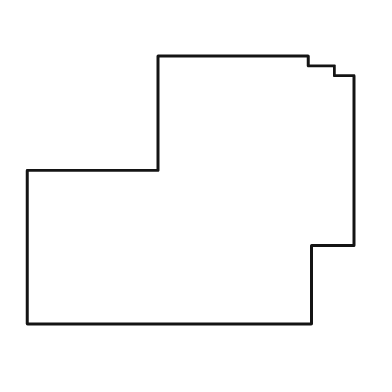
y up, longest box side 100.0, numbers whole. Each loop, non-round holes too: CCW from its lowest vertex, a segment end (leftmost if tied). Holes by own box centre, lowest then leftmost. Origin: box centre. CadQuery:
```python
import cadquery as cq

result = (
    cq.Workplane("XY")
    .moveTo(-50.0, -41.0)
    .lineTo(37.0, -41.0)
    .lineTo(37.0, -17.0)
    .lineTo(50.0, -17.0)
    .lineTo(50.0, 35.0)
    .lineTo(44.0, 35.0)
    .lineTo(44.0, 38.0)
    .lineTo(36.0, 38.0)
    .lineTo(36.0, 41.0)
    .lineTo(-10.0, 41.0)
    .lineTo(-10.0, 6.0)
    .lineTo(-50.0, 6.0)
    .close()
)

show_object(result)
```